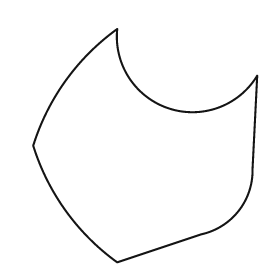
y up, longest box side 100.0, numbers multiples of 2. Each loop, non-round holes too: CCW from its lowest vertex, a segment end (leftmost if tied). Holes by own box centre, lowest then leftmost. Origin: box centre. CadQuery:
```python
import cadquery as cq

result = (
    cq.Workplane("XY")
    .moveTo(-12.0, -50.0)
    .lineTo(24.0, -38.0)
    .threePointArc((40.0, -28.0), (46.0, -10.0))
    .lineTo(48.0, 30.0)
    .threePointArc((10.0, 16.0), (-12.0, 50.0))
    .threePointArc((-34.0, 28.0), (-48.0, 0.0))
    .threePointArc((-34.0, -28.0), (-12.0, -50.0))
    .close()
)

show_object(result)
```